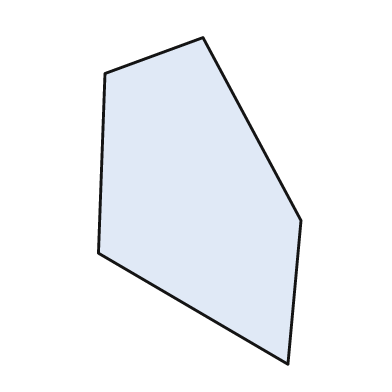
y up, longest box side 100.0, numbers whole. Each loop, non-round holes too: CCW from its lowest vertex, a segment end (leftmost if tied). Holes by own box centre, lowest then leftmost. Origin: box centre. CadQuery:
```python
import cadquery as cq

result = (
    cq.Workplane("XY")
    .moveTo(27.0, -50.0)
    .lineTo(31.0, -6.0)
    .lineTo(1.0, 50.0)
    .lineTo(-29.0, 39.0)
    .lineTo(-31.0, -16.0)
    .close()
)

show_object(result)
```